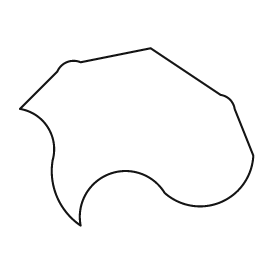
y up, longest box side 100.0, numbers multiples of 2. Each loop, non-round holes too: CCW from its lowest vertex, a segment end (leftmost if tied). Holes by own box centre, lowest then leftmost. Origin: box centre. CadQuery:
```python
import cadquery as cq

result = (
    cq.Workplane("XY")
    .moveTo(-24.0, -38.0)
    .threePointArc((-12.0, -16.0), (12.0, -24.0))
    .threePointArc((36.0, -28.0), (50.0, -8.0))
    .lineTo(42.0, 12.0)
    .threePointArc((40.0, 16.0), (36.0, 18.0))
    .lineTo(6.0, 38.0)
    .lineTo(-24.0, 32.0)
    .threePointArc((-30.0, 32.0), (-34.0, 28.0))
    .lineTo(-50.0, 12.0)
    .threePointArc((-38.0, 4.0), (-36.0, -10.0))
    .threePointArc((-34.0, -26.0), (-24.0, -38.0))
    .close()
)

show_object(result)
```